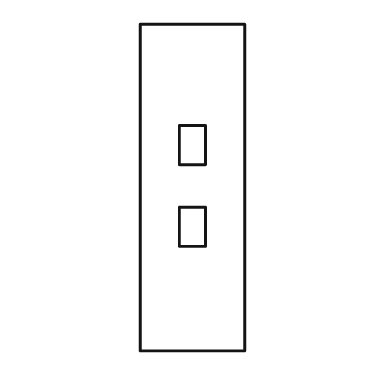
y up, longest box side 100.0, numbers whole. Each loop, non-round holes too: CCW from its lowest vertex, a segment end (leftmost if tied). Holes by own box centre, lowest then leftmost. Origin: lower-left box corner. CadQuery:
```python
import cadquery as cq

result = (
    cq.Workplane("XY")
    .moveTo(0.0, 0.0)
    .lineTo(32.0, 0.0)
    .lineTo(32.0, 100.0)
    .lineTo(0.0, 100.0)
    .close()
    .moveTo(12.0, 32.0)
    .lineTo(20.0, 32.0)
    .lineTo(20.0, 44.0)
    .lineTo(12.0, 44.0)
    .close()
    .moveTo(12.0, 57.0)
    .lineTo(20.0, 57.0)
    .lineTo(20.0, 69.0)
    .lineTo(12.0, 69.0)
    .close()
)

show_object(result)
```